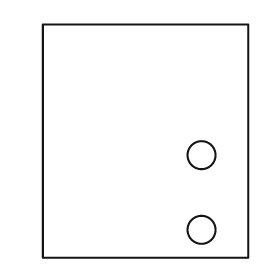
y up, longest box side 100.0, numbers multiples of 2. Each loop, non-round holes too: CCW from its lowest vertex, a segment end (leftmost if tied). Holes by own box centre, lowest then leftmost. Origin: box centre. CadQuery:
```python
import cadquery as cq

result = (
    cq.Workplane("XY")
    .moveTo(-44.0, -50.0)
    .lineTo(44.0, -50.0)
    .lineTo(44.0, 50.0)
    .lineTo(-44.0, 50.0)
    .close()
    .moveTo(24.0, -38.0)
    .circle(6.0)
    .moveTo(24.0, -6.0)
    .circle(6.0)
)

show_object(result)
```